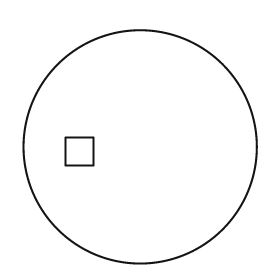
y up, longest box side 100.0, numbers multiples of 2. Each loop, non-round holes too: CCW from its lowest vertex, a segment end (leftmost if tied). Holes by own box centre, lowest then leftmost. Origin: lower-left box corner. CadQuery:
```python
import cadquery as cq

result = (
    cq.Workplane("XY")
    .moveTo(50.0, 50.0)
    .circle(50.0)
    .moveTo(18.0, 42.0)
    .lineTo(30.0, 42.0)
    .lineTo(30.0, 54.0)
    .lineTo(18.0, 54.0)
    .close()
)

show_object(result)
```